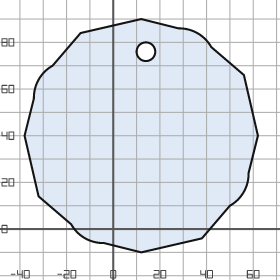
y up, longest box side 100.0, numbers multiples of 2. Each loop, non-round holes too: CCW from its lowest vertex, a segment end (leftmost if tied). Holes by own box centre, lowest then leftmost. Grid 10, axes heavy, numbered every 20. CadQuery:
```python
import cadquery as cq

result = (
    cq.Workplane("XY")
    .moveTo(12.0, -10.0)
    .lineTo(38.0, -4.0)
    .lineTo(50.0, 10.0)
    .threePointArc((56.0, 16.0), (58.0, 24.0))
    .lineTo(62.0, 40.0)
    .lineTo(56.0, 66.0)
    .lineTo(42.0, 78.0)
    .threePointArc((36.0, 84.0), (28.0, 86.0))
    .lineTo(12.0, 90.0)
    .lineTo(-14.0, 84.0)
    .lineTo(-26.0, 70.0)
    .threePointArc((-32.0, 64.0), (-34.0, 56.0))
    .lineTo(-38.0, 40.0)
    .lineTo(-32.0, 14.0)
    .lineTo(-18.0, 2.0)
    .threePointArc((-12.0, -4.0), (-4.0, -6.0))
    .close()
    .moveTo(14.0, 76.0)
    .circle(4.0)
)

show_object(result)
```